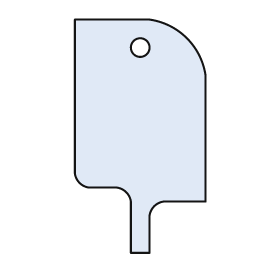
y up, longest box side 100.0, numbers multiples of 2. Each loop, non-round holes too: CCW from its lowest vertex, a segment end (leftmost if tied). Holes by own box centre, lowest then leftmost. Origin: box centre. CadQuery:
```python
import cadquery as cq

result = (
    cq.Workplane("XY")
    .moveTo(-4.0, -50.0)
    .lineTo(4.0, -50.0)
    .lineTo(4.0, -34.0)
    .threePointArc((6.0, -30.0), (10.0, -28.0))
    .lineTo(28.0, -28.0)
    .lineTo(28.0, 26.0)
    .threePointArc((20.0, 42.0), (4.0, 50.0))
    .lineTo(-28.0, 50.0)
    .lineTo(-28.0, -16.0)
    .threePointArc((-26.0, -20.0), (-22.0, -22.0))
    .lineTo(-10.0, -22.0)
    .threePointArc((-6.0, -24.0), (-4.0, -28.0))
    .close()
    .moveTo(0.0, 38.0)
    .circle(4.0)
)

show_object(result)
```